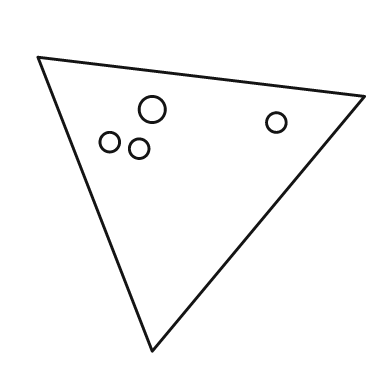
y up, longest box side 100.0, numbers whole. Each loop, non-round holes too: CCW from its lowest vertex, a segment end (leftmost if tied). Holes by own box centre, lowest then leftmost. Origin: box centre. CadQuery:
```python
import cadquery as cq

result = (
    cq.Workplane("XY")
    .moveTo(-15.0, -45.0)
    .lineTo(50.0, 33.0)
    .lineTo(-50.0, 45.0)
    .close()
    .moveTo(-19.0, 17.0)
    .circle(3.0)
    .moveTo(-28.0, 19.0)
    .circle(3.0)
    .moveTo(23.0, 25.0)
    .circle(3.0)
    .moveTo(-15.0, 29.0)
    .circle(4.0)
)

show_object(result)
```